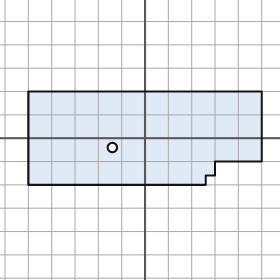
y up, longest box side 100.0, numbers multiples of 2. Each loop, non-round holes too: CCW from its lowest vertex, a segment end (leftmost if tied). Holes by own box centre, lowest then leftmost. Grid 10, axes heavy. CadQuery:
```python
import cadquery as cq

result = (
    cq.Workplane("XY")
    .moveTo(-50.0, -20.0)
    .lineTo(26.0, -20.0)
    .lineTo(26.0, -16.0)
    .lineTo(30.0, -16.0)
    .lineTo(30.0, -10.0)
    .lineTo(50.0, -10.0)
    .lineTo(50.0, 20.0)
    .lineTo(-50.0, 20.0)
    .close()
    .moveTo(-14.0, -4.0)
    .circle(2.0)
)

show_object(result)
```